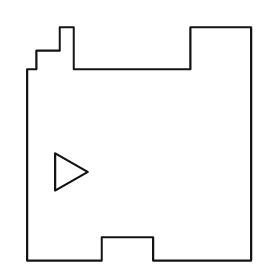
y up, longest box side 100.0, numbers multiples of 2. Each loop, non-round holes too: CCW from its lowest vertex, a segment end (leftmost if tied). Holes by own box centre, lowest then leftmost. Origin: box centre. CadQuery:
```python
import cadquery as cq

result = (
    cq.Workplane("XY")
    .moveTo(-48.0, -50.0)
    .lineTo(-16.0, -50.0)
    .lineTo(-16.0, -40.0)
    .lineTo(6.0, -40.0)
    .lineTo(6.0, -50.0)
    .lineTo(48.0, -50.0)
    .lineTo(48.0, 50.0)
    .lineTo(22.0, 50.0)
    .lineTo(22.0, 32.0)
    .lineTo(-28.0, 32.0)
    .lineTo(-28.0, 50.0)
    .lineTo(-34.0, 50.0)
    .lineTo(-34.0, 40.0)
    .lineTo(-44.0, 40.0)
    .lineTo(-44.0, 32.0)
    .lineTo(-48.0, 32.0)
    .close()
    .moveTo(-36.0, -20.0)
    .lineTo(-22.0, -12.0)
    .lineTo(-36.0, -4.0)
    .close()
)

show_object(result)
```